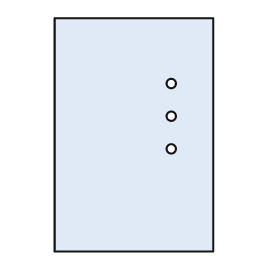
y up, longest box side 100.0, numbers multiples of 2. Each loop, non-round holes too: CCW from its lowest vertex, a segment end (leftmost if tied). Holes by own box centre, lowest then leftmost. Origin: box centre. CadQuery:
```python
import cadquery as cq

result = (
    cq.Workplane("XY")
    .moveTo(-34.0, -50.0)
    .lineTo(34.0, -50.0)
    .lineTo(34.0, 50.0)
    .lineTo(-34.0, 50.0)
    .close()
    .moveTo(16.0, -6.0)
    .circle(2.0)
    .moveTo(16.0, 8.0)
    .circle(2.0)
    .moveTo(16.0, 22.0)
    .circle(2.0)
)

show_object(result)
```